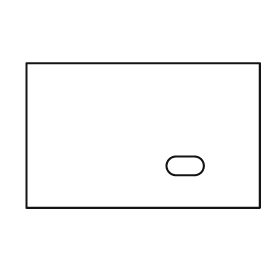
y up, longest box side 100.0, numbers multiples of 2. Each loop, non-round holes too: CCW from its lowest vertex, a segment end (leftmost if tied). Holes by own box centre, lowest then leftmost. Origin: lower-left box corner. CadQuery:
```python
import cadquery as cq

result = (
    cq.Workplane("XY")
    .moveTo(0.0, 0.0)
    .lineTo(100.0, 0.0)
    .lineTo(100.0, 62.0)
    .lineTo(0.0, 62.0)
    .close()
    .moveTo(64.0, 14.0)
    .lineTo(72.0, 14.0)
    .threePointArc((76.0, 18.0), (72.0, 22.0))
    .lineTo(64.0, 22.0)
    .threePointArc((60.0, 18.0), (64.0, 14.0))
    .close()
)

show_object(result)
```